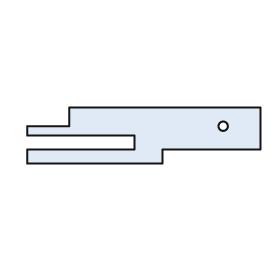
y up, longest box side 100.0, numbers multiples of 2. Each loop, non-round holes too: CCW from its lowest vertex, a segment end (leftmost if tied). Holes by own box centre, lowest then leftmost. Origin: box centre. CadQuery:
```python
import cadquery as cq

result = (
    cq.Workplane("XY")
    .moveTo(-50.0, -12.0)
    .lineTo(8.0, -12.0)
    .lineTo(8.0, -6.0)
    .lineTo(50.0, -6.0)
    .lineTo(50.0, 12.0)
    .lineTo(-32.0, 12.0)
    .lineTo(-32.0, 4.0)
    .lineTo(-50.0, 4.0)
    .lineTo(-50.0, 0.0)
    .lineTo(-4.0, 0.0)
    .lineTo(-4.0, -6.0)
    .lineTo(-50.0, -6.0)
    .close()
    .moveTo(34.0, 4.0)
    .circle(2.0)
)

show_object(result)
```